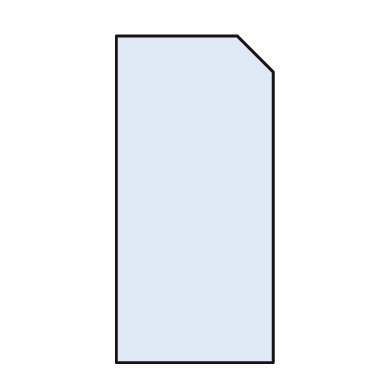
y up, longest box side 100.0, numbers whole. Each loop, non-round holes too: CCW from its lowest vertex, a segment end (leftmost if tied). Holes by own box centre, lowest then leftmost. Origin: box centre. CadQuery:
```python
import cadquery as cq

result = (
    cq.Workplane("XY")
    .moveTo(-24.0, -50.0)
    .lineTo(24.0, -50.0)
    .lineTo(24.0, 39.0)
    .lineTo(13.0, 50.0)
    .lineTo(-24.0, 50.0)
    .close()
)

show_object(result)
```